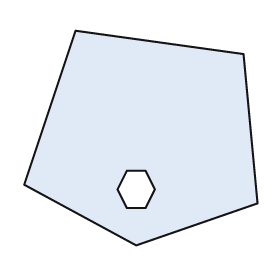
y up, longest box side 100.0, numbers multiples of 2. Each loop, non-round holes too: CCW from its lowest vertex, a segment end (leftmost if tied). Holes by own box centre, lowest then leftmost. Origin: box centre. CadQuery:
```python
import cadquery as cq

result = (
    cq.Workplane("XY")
    .moveTo(-2.0, -46.0)
    .lineTo(50.0, -28.0)
    .lineTo(44.0, 36.0)
    .lineTo(-28.0, 46.0)
    .lineTo(-50.0, -20.0)
    .close()
    .moveTo(-6.0, -30.0)
    .lineTo(2.0, -30.0)
    .lineTo(6.0, -22.0)
    .lineTo(2.0, -14.0)
    .lineTo(-6.0, -14.0)
    .lineTo(-10.0, -22.0)
    .close()
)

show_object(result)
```